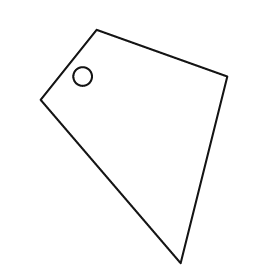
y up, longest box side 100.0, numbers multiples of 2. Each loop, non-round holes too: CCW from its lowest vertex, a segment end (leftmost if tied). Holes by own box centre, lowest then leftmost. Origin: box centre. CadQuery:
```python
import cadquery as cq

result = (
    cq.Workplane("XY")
    .moveTo(20.0, -50.0)
    .lineTo(40.0, 30.0)
    .lineTo(-16.0, 50.0)
    .lineTo(-40.0, 20.0)
    .close()
    .moveTo(-22.0, 30.0)
    .circle(4.0)
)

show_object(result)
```